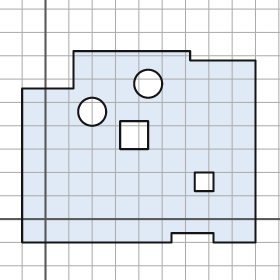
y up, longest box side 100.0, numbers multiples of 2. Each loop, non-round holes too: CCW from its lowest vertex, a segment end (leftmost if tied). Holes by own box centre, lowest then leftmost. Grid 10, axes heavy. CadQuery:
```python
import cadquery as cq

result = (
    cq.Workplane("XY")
    .moveTo(-10.0, -10.0)
    .lineTo(54.0, -10.0)
    .lineTo(54.0, -6.0)
    .lineTo(72.0, -6.0)
    .lineTo(72.0, -10.0)
    .lineTo(90.0, -10.0)
    .lineTo(90.0, 68.0)
    .lineTo(62.0, 68.0)
    .lineTo(62.0, 72.0)
    .lineTo(12.0, 72.0)
    .lineTo(12.0, 56.0)
    .lineTo(-10.0, 56.0)
    .close()
    .moveTo(64.0, 12.0)
    .lineTo(72.0, 12.0)
    .lineTo(72.0, 20.0)
    .lineTo(64.0, 20.0)
    .close()
    .moveTo(32.0, 30.0)
    .lineTo(44.0, 30.0)
    .lineTo(44.0, 42.0)
    .lineTo(32.0, 42.0)
    .close()
    .moveTo(20.0, 46.0)
    .circle(6.0)
    .moveTo(44.0, 58.0)
    .circle(6.0)
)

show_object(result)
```